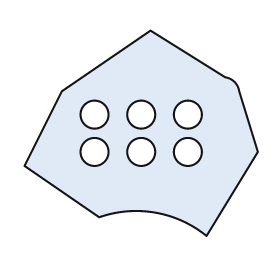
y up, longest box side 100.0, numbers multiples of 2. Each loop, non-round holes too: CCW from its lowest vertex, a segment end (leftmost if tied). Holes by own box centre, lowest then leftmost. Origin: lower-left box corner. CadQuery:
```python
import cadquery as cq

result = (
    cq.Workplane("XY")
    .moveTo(78.0, 0.0)
    .lineTo(100.0, 36.0)
    .lineTo(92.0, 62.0)
    .threePointArc((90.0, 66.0), (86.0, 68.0))
    .lineTo(54.0, 88.0)
    .lineTo(16.0, 62.0)
    .lineTo(0.0, 30.0)
    .lineTo(32.0, 8.0)
    .threePointArc((56.0, 10.0), (78.0, 0.0))
    .close()
    .moveTo(30.0, 36.0)
    .circle(6.0)
    .moveTo(50.0, 36.0)
    .circle(6.0)
    .moveTo(70.0, 36.0)
    .circle(6.0)
    .moveTo(30.0, 52.0)
    .circle(6.0)
    .moveTo(50.0, 52.0)
    .circle(6.0)
    .moveTo(70.0, 52.0)
    .circle(6.0)
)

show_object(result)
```